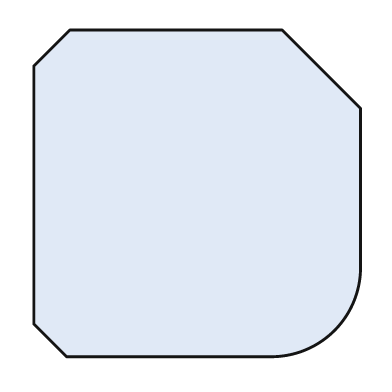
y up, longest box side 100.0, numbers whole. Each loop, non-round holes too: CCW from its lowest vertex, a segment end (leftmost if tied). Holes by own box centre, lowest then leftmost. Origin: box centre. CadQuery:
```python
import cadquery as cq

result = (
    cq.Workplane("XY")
    .moveTo(-40.0, -50.0)
    .lineTo(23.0, -50.0)
    .threePointArc((42.0, -42.0), (50.0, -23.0))
    .lineTo(50.0, 26.0)
    .lineTo(26.0, 50.0)
    .lineTo(-39.0, 50.0)
    .lineTo(-50.0, 39.0)
    .lineTo(-50.0, -40.0)
    .close()
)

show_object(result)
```